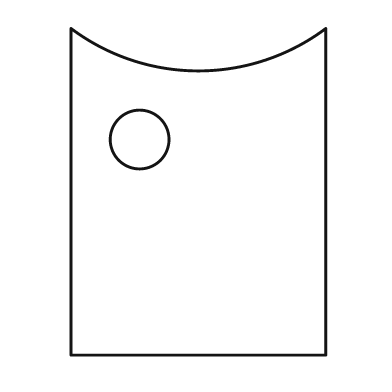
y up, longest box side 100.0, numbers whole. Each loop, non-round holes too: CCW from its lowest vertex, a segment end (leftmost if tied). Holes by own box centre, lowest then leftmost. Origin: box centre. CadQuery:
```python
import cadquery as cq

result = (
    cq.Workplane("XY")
    .moveTo(-39.0, -50.0)
    .lineTo(39.0, -50.0)
    .lineTo(39.0, 50.0)
    .threePointArc((0.0, 37.0), (-39.0, 50.0))
    .close()
    .moveTo(-18.0, 16.0)
    .circle(9.0)
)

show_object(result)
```